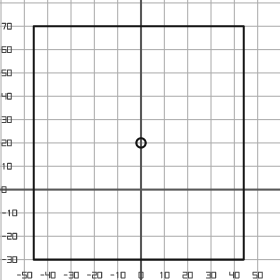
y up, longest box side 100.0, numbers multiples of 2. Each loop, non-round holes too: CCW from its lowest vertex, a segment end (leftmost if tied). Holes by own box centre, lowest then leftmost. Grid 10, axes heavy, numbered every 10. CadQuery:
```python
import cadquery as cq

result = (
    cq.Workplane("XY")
    .moveTo(-46.0, -30.0)
    .lineTo(44.0, -30.0)
    .lineTo(44.0, 70.0)
    .lineTo(-46.0, 70.0)
    .close()
    .moveTo(0.0, 20.0)
    .circle(2.0)
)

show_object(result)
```